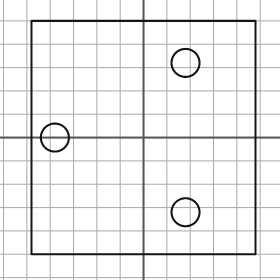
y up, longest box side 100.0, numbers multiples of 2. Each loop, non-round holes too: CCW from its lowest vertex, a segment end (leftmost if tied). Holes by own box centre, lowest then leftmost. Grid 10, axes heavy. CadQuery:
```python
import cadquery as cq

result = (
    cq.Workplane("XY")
    .moveTo(-48.0, -50.0)
    .lineTo(48.0, -50.0)
    .lineTo(48.0, 50.0)
    .lineTo(-48.0, 50.0)
    .close()
    .moveTo(18.0, -32.0)
    .circle(6.0)
    .moveTo(-38.0, 0.0)
    .circle(6.0)
    .moveTo(18.0, 32.0)
    .circle(6.0)
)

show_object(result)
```